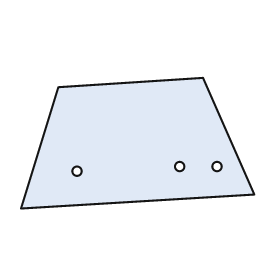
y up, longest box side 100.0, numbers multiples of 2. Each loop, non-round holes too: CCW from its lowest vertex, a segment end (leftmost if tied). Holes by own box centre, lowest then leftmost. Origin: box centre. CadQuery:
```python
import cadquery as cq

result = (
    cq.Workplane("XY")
    .moveTo(-50.0, -28.0)
    .lineTo(50.0, -22.0)
    .lineTo(28.0, 28.0)
    .lineTo(-34.0, 24.0)
    .close()
    .moveTo(-26.0, -12.0)
    .circle(2.0)
    .moveTo(18.0, -10.0)
    .circle(2.0)
    .moveTo(34.0, -10.0)
    .circle(2.0)
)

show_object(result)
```